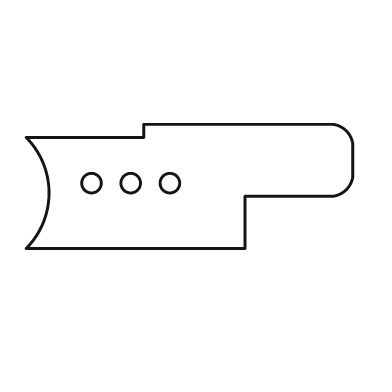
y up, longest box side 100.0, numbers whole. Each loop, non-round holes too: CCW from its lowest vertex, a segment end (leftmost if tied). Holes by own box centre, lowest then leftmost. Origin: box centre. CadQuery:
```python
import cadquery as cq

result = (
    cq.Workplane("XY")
    .moveTo(-50.0, -19.0)
    .lineTo(17.0, -19.0)
    .lineTo(17.0, -3.0)
    .lineTo(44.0, -3.0)
    .threePointArc((48.0, -1.0), (50.0, 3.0))
    .lineTo(50.0, 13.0)
    .threePointArc((48.0, 17.0), (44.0, 19.0))
    .lineTo(-14.0, 19.0)
    .lineTo(-14.0, 15.0)
    .lineTo(-50.0, 15.0)
    .threePointArc((-43.0, -2.0), (-50.0, -19.0))
    .close()
    .moveTo(-30.0, 1.0)
    .circle(3.0)
    .moveTo(-18.0, 1.0)
    .circle(3.0)
    .moveTo(-6.0, 1.0)
    .circle(3.0)
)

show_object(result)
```